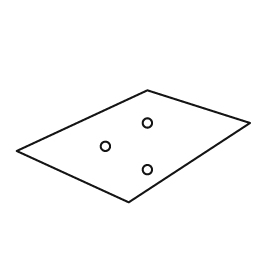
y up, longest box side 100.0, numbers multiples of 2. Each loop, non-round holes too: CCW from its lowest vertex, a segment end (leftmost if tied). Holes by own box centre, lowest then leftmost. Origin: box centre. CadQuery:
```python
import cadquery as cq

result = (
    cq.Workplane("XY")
    .moveTo(-2.0, -24.0)
    .lineTo(50.0, 10.0)
    .lineTo(6.0, 24.0)
    .lineTo(-50.0, -2.0)
    .close()
    .moveTo(6.0, -10.0)
    .circle(2.0)
    .moveTo(-12.0, 0.0)
    .circle(2.0)
    .moveTo(6.0, 10.0)
    .circle(2.0)
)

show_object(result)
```